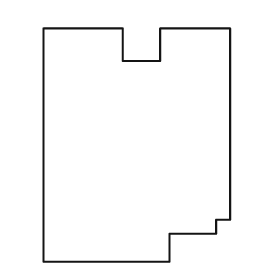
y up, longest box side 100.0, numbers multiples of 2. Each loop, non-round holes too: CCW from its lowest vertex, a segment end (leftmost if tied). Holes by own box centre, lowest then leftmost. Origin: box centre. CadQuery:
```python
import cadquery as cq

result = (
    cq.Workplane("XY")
    .moveTo(-40.0, -50.0)
    .lineTo(14.0, -50.0)
    .lineTo(14.0, -38.0)
    .lineTo(34.0, -38.0)
    .lineTo(34.0, -32.0)
    .lineTo(40.0, -32.0)
    .lineTo(40.0, 50.0)
    .lineTo(10.0, 50.0)
    .lineTo(10.0, 36.0)
    .lineTo(-6.0, 36.0)
    .lineTo(-6.0, 50.0)
    .lineTo(-40.0, 50.0)
    .close()
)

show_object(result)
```